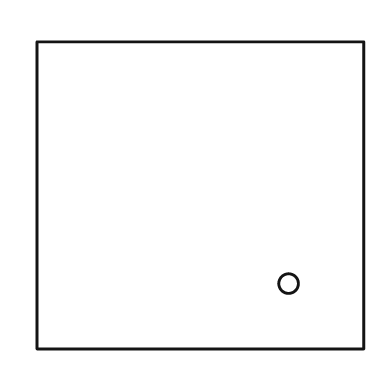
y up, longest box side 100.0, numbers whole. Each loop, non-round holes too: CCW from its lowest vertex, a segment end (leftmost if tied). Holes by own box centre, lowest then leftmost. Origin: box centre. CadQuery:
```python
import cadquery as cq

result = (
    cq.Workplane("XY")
    .moveTo(-50.0, -47.0)
    .lineTo(50.0, -47.0)
    .lineTo(50.0, 47.0)
    .lineTo(-50.0, 47.0)
    .close()
    .moveTo(27.0, -27.0)
    .circle(3.0)
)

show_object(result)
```